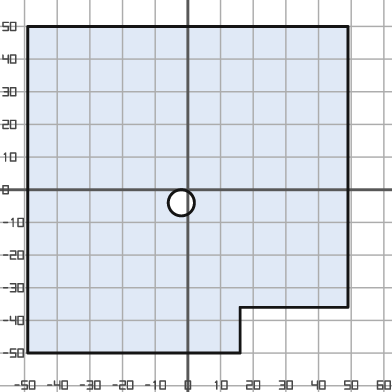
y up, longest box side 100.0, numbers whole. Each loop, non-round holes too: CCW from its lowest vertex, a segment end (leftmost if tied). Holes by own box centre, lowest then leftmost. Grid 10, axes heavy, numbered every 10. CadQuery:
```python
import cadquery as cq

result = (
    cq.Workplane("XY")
    .moveTo(-49.0, -50.0)
    .lineTo(16.0, -50.0)
    .lineTo(16.0, -36.0)
    .lineTo(49.0, -36.0)
    .lineTo(49.0, 50.0)
    .lineTo(-49.0, 50.0)
    .close()
    .moveTo(-2.0, -4.0)
    .circle(4.0)
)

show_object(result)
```